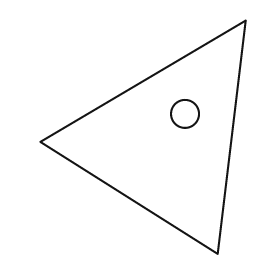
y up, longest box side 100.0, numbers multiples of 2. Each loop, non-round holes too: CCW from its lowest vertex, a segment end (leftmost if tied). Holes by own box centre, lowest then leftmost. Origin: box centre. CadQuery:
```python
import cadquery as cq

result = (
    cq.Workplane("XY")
    .moveTo(32.0, -50.0)
    .lineTo(44.0, 50.0)
    .lineTo(-44.0, -2.0)
    .close()
    .moveTo(18.0, 10.0)
    .circle(6.0)
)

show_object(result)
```